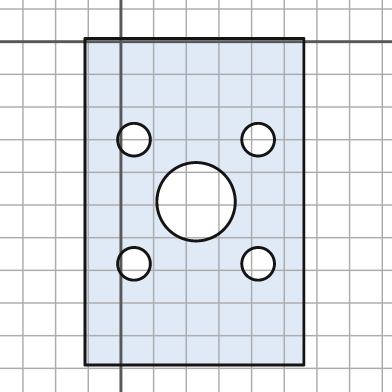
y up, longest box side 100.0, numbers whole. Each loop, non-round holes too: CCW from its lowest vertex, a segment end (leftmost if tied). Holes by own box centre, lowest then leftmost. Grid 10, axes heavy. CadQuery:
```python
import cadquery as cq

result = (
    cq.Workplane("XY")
    .moveTo(-11.0, -99.0)
    .lineTo(56.0, -99.0)
    .lineTo(56.0, 1.0)
    .lineTo(-11.0, 1.0)
    .close()
    .moveTo(4.0, -68.0)
    .circle(5.0)
    .moveTo(42.0, -68.0)
    .circle(5.0)
    .moveTo(23.0, -49.0)
    .circle(12.0)
    .moveTo(4.0, -30.0)
    .circle(5.0)
    .moveTo(42.0, -30.0)
    .circle(5.0)
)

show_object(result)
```